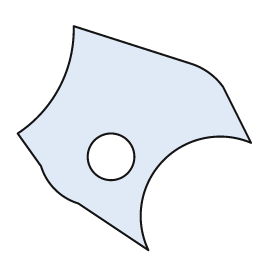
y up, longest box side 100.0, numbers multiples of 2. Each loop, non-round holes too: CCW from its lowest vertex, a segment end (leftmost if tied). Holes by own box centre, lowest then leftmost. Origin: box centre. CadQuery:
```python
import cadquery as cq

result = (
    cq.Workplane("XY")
    .moveTo(6.0, -48.0)
    .threePointArc((12.0, -10.0), (50.0, -2.0))
    .lineTo(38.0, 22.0)
    .threePointArc((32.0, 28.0), (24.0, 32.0))
    .lineTo(-26.0, 48.0)
    .threePointArc((-32.0, 22.0), (-50.0, 2.0))
    .lineTo(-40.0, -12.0)
    .threePointArc((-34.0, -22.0), (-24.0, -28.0))
    .close()
    .moveTo(-10.0, -8.0)
    .circle(10.0)
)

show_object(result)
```